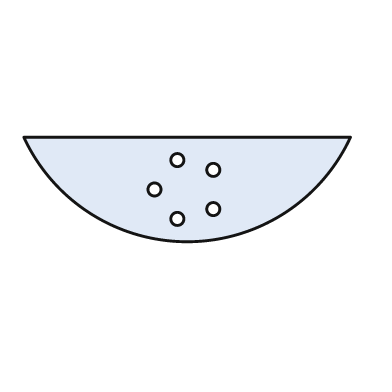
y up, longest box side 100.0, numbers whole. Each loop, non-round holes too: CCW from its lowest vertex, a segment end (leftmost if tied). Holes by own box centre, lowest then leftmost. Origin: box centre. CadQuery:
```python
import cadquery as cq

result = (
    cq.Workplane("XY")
    .moveTo(-50.0, 16.0)
    .threePointArc((0.0, -16.0), (50.0, 16.0))
    .close()
    .moveTo(-3.0, -9.0)
    .circle(2.0)
    .moveTo(8.0, -6.0)
    .circle(2.0)
    .moveTo(-10.0, 0.0)
    .circle(2.0)
    .moveTo(8.0, 6.0)
    .circle(2.0)
    .moveTo(-3.0, 9.0)
    .circle(2.0)
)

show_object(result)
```